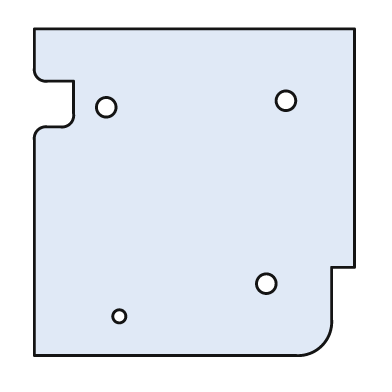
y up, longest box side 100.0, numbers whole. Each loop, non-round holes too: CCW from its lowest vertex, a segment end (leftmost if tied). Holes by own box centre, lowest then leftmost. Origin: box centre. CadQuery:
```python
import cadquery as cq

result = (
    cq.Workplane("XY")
    .moveTo(-49.0, -50.0)
    .lineTo(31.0, -50.0)
    .threePointArc((39.0, -47.0), (42.0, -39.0))
    .lineTo(42.0, -23.0)
    .lineTo(49.0, -23.0)
    .lineTo(49.0, 50.0)
    .lineTo(-49.0, 50.0)
    .lineTo(-49.0, 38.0)
    .threePointArc((-48.0, 35.0), (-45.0, 34.0))
    .lineTo(-37.0, 34.0)
    .lineTo(-37.0, 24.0)
    .threePointArc((-38.0, 21.0), (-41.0, 20.0))
    .lineTo(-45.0, 20.0)
    .threePointArc((-48.0, 19.0), (-49.0, 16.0))
    .close()
    .moveTo(-23.0, -38.0)
    .circle(2.0)
    .moveTo(22.0, -28.0)
    .circle(3.0)
    .moveTo(-27.0, 26.0)
    .circle(3.0)
    .moveTo(28.0, 28.0)
    .circle(3.0)
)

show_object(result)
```